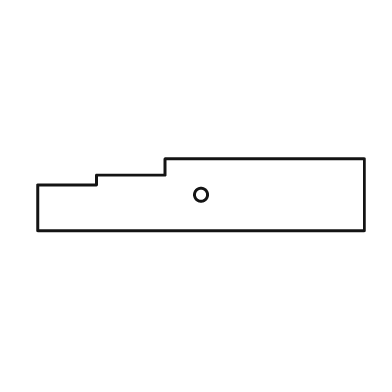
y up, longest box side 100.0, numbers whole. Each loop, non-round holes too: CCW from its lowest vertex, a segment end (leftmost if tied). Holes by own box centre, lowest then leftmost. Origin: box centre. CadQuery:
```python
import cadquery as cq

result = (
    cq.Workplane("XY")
    .moveTo(-50.0, -11.0)
    .lineTo(50.0, -11.0)
    .lineTo(50.0, 11.0)
    .lineTo(-11.0, 11.0)
    .lineTo(-11.0, 6.0)
    .lineTo(-32.0, 6.0)
    .lineTo(-32.0, 3.0)
    .lineTo(-50.0, 3.0)
    .close()
    .moveTo(0.0, 0.0)
    .circle(2.0)
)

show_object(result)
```